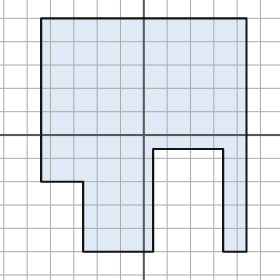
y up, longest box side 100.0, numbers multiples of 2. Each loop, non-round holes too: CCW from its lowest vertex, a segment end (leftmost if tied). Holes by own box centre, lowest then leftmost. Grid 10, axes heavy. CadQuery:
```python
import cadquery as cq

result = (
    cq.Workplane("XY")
    .moveTo(-26.0, -50.0)
    .lineTo(4.0, -50.0)
    .lineTo(4.0, -6.0)
    .lineTo(34.0, -6.0)
    .lineTo(34.0, -50.0)
    .lineTo(44.0, -50.0)
    .lineTo(44.0, 50.0)
    .lineTo(-44.0, 50.0)
    .lineTo(-44.0, -20.0)
    .lineTo(-26.0, -20.0)
    .close()
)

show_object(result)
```